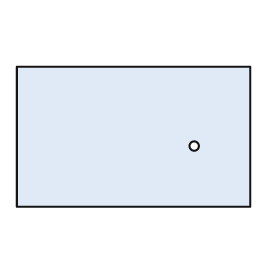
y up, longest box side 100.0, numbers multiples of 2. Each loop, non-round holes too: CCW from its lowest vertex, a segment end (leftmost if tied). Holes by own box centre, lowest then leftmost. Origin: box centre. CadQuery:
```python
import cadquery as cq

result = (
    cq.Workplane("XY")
    .moveTo(-50.0, -30.0)
    .lineTo(50.0, -30.0)
    .lineTo(50.0, 30.0)
    .lineTo(-50.0, 30.0)
    .close()
    .moveTo(26.0, -4.0)
    .circle(2.0)
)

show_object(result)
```